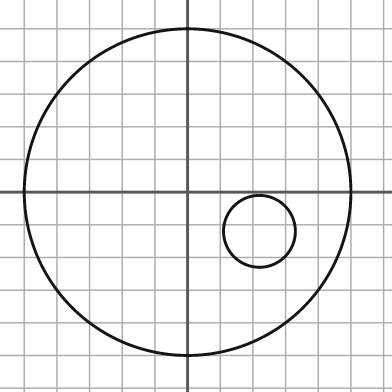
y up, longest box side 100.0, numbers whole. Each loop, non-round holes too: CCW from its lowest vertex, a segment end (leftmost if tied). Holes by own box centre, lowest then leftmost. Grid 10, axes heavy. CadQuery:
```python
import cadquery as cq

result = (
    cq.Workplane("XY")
    .moveTo(0.0, 0.0)
    .circle(50.0)
    .moveTo(22.0, -12.0)
    .circle(11.0)
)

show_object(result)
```